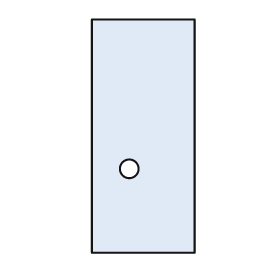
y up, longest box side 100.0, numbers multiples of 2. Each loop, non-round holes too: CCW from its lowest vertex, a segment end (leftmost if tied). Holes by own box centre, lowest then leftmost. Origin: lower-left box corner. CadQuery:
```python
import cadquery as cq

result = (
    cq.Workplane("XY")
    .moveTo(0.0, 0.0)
    .lineTo(44.0, 0.0)
    .lineTo(44.0, 100.0)
    .lineTo(0.0, 100.0)
    .close()
    .moveTo(16.0, 36.0)
    .circle(4.0)
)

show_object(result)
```